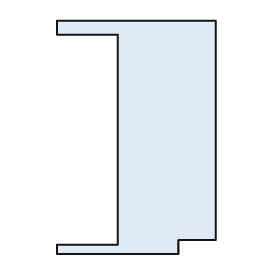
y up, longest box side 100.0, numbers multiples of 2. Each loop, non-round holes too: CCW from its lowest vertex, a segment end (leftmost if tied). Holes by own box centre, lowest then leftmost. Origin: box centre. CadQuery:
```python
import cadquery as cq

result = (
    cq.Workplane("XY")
    .moveTo(-34.0, -50.0)
    .lineTo(18.0, -50.0)
    .lineTo(18.0, -44.0)
    .lineTo(34.0, -44.0)
    .lineTo(34.0, 50.0)
    .lineTo(-34.0, 50.0)
    .lineTo(-34.0, 44.0)
    .lineTo(-8.0, 44.0)
    .lineTo(-8.0, -46.0)
    .lineTo(-34.0, -46.0)
    .close()
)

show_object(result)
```